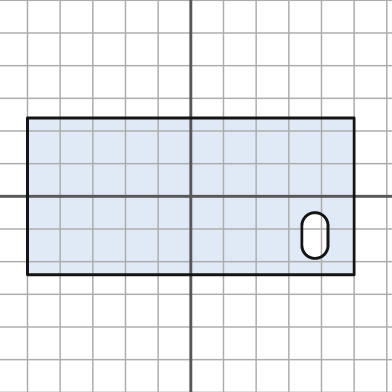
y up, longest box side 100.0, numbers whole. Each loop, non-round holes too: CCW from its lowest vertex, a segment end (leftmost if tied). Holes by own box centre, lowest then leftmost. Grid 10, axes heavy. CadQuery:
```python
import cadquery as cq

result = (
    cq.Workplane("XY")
    .moveTo(-50.0, -24.0)
    .lineTo(50.0, -24.0)
    .lineTo(50.0, 24.0)
    .lineTo(-50.0, 24.0)
    .close()
    .moveTo(34.0, -15.0)
    .threePointArc((38.0, -19.0), (42.0, -15.0))
    .lineTo(42.0, -9.0)
    .threePointArc((38.0, -5.0), (34.0, -9.0))
    .close()
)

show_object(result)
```